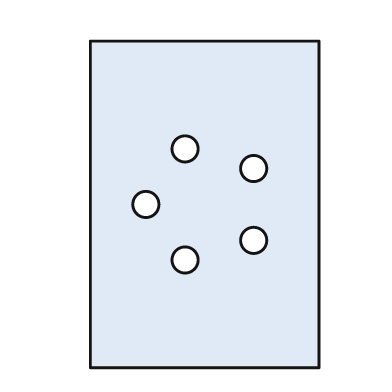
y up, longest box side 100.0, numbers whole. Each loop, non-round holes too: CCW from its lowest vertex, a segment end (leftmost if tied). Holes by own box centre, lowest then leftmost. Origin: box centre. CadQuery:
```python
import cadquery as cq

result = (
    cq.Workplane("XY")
    .moveTo(-35.0, -50.0)
    .lineTo(35.0, -50.0)
    .lineTo(35.0, 50.0)
    .lineTo(-35.0, 50.0)
    .close()
    .moveTo(-6.0, -17.0)
    .circle(4.0)
    .moveTo(15.0, -11.0)
    .circle(4.0)
    .moveTo(-18.0, 0.0)
    .circle(4.0)
    .moveTo(15.0, 11.0)
    .circle(4.0)
    .moveTo(-6.0, 17.0)
    .circle(4.0)
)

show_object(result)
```